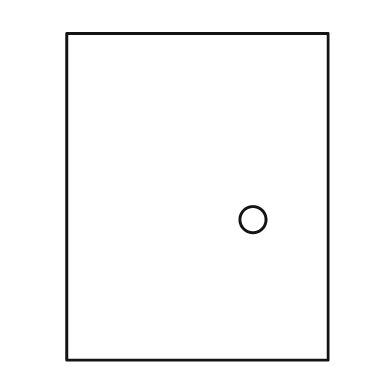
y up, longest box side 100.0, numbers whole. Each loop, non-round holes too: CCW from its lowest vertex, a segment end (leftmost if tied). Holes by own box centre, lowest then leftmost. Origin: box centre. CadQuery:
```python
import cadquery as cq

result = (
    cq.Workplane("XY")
    .moveTo(-40.0, -50.0)
    .lineTo(40.0, -50.0)
    .lineTo(40.0, 50.0)
    .lineTo(-40.0, 50.0)
    .close()
    .moveTo(17.0, -7.0)
    .circle(4.0)
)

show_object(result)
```